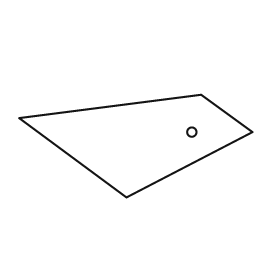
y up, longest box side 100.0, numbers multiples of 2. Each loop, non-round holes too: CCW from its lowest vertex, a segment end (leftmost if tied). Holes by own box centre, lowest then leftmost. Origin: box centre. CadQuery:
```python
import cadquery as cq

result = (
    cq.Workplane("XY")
    .moveTo(-4.0, -22.0)
    .lineTo(50.0, 6.0)
    .lineTo(28.0, 22.0)
    .lineTo(-50.0, 12.0)
    .close()
    .moveTo(24.0, 6.0)
    .circle(2.0)
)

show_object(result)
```